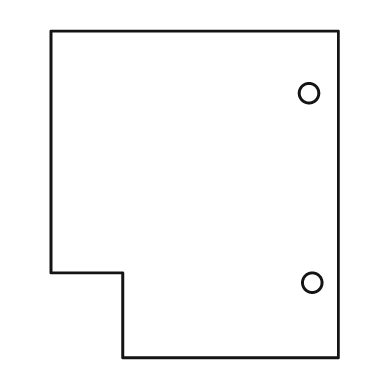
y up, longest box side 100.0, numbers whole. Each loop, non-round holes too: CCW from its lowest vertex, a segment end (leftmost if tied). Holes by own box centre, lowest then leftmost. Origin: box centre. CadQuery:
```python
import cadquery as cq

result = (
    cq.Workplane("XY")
    .moveTo(-22.0, -50.0)
    .lineTo(44.0, -50.0)
    .lineTo(44.0, 50.0)
    .lineTo(-44.0, 50.0)
    .lineTo(-44.0, -24.0)
    .lineTo(-22.0, -24.0)
    .close()
    .moveTo(36.0, -27.0)
    .circle(3.0)
    .moveTo(35.0, 31.0)
    .circle(3.0)
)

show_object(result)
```